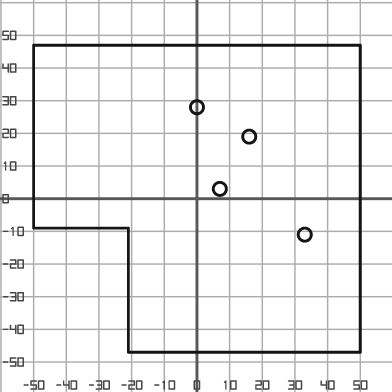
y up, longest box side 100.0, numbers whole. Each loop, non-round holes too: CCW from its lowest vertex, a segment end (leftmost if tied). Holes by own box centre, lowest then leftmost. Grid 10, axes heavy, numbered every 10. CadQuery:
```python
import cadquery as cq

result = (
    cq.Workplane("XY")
    .moveTo(-21.0, -47.0)
    .lineTo(50.0, -47.0)
    .lineTo(50.0, 47.0)
    .lineTo(-50.0, 47.0)
    .lineTo(-50.0, -9.0)
    .lineTo(-21.0, -9.0)
    .close()
    .moveTo(33.0, -11.0)
    .circle(2.0)
    .moveTo(7.0, 3.0)
    .circle(2.0)
    .moveTo(16.0, 19.0)
    .circle(2.0)
    .moveTo(0.0, 28.0)
    .circle(2.0)
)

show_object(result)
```